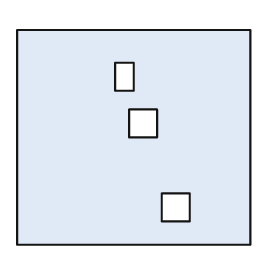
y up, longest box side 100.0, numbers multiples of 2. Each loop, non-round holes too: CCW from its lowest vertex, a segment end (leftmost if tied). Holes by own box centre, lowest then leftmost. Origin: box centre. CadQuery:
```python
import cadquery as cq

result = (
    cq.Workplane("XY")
    .moveTo(-50.0, -46.0)
    .lineTo(50.0, -46.0)
    .lineTo(50.0, 46.0)
    .lineTo(-50.0, 46.0)
    .close()
    .moveTo(12.0, -36.0)
    .lineTo(24.0, -36.0)
    .lineTo(24.0, -24.0)
    .lineTo(12.0, -24.0)
    .close()
    .moveTo(-2.0, 0.0)
    .lineTo(10.0, 0.0)
    .lineTo(10.0, 12.0)
    .lineTo(-2.0, 12.0)
    .close()
    .moveTo(-8.0, 20.0)
    .lineTo(0.0, 20.0)
    .lineTo(0.0, 32.0)
    .lineTo(-8.0, 32.0)
    .close()
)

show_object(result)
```